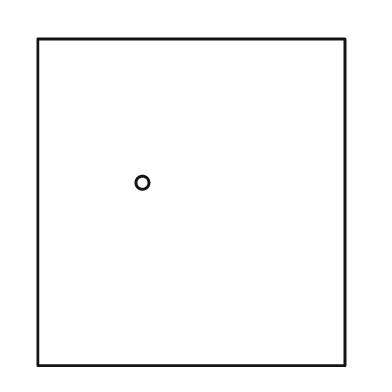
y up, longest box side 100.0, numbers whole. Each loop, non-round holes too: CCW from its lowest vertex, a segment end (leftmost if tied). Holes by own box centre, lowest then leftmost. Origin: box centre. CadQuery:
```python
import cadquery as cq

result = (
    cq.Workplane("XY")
    .moveTo(-47.0, -50.0)
    .lineTo(47.0, -50.0)
    .lineTo(47.0, 50.0)
    .lineTo(-47.0, 50.0)
    .close()
    .moveTo(-15.0, 6.0)
    .circle(2.0)
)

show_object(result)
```